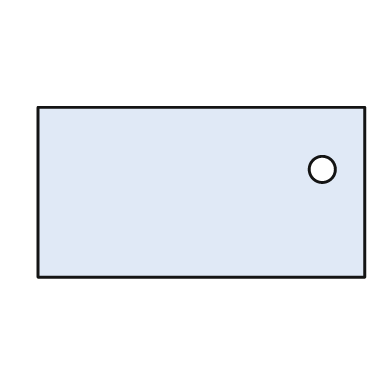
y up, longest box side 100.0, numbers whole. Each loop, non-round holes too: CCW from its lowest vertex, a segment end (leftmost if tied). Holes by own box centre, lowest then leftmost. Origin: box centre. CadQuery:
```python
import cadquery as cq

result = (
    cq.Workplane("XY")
    .moveTo(-50.0, -26.0)
    .lineTo(50.0, -26.0)
    .lineTo(50.0, 26.0)
    .lineTo(-50.0, 26.0)
    .close()
    .moveTo(37.0, 7.0)
    .circle(4.0)
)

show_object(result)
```